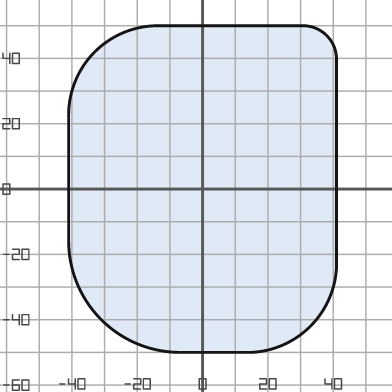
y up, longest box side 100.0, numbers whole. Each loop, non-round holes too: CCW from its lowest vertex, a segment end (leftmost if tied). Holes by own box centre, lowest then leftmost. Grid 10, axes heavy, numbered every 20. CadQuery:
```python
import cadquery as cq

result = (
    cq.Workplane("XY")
    .moveTo(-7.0, -50.0)
    .lineTo(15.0, -50.0)
    .threePointArc((33.0, -42.0), (41.0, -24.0))
    .lineTo(41.0, 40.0)
    .threePointArc((38.0, 47.0), (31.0, 50.0))
    .lineTo(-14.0, 50.0)
    .threePointArc((-33.0, 42.0), (-41.0, 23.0))
    .lineTo(-41.0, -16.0)
    .threePointArc((-31.0, -40.0), (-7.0, -50.0))
    .close()
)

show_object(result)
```